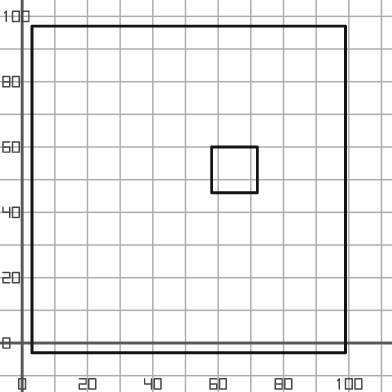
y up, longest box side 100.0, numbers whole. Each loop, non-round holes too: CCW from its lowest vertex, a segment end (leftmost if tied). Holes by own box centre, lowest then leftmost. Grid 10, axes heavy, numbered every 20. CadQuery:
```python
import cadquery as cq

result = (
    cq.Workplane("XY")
    .moveTo(3.0, -3.0)
    .lineTo(99.0, -3.0)
    .lineTo(99.0, 97.0)
    .lineTo(3.0, 97.0)
    .close()
    .moveTo(58.0, 46.0)
    .lineTo(72.0, 46.0)
    .lineTo(72.0, 60.0)
    .lineTo(58.0, 60.0)
    .close()
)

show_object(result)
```